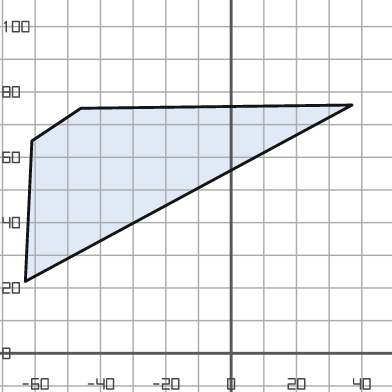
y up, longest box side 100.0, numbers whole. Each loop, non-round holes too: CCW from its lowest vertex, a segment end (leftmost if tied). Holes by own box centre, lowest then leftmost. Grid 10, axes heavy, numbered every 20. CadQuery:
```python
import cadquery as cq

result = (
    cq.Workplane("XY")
    .moveTo(-63.0, 22.0)
    .lineTo(37.0, 76.0)
    .lineTo(-46.0, 75.0)
    .lineTo(-61.0, 65.0)
    .close()
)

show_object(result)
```